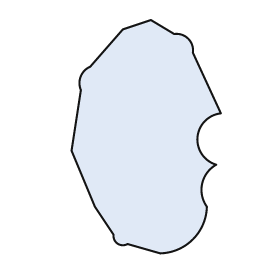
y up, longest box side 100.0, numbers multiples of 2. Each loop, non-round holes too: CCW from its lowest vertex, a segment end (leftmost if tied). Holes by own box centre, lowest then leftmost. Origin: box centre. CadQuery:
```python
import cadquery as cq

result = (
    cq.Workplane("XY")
    .moveTo(6.0, -50.0)
    .threePointArc((20.0, -44.0), (26.0, -30.0))
    .threePointArc((24.0, -20.0), (30.0, -12.0))
    .threePointArc((22.0, 0.0), (32.0, 10.0))
    .lineTo(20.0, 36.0)
    .threePointArc((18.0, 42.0), (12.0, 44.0))
    .lineTo(2.0, 50.0)
    .lineTo(-10.0, 46.0)
    .lineTo(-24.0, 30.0)
    .threePointArc((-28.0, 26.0), (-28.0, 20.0))
    .lineTo(-32.0, -6.0)
    .lineTo(-22.0, -30.0)
    .lineTo(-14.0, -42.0)
    .threePointArc((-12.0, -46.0), (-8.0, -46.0))
    .close()
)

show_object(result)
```